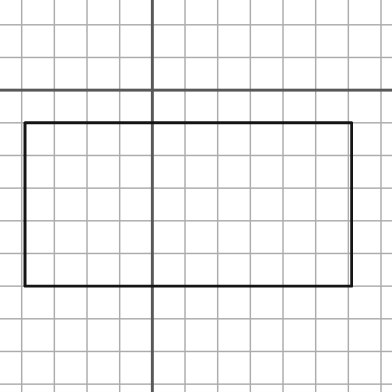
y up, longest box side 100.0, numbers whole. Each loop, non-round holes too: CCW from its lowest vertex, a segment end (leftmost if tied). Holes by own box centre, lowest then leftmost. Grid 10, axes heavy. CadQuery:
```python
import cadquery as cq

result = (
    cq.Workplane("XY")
    .moveTo(-39.0, -60.0)
    .lineTo(61.0, -60.0)
    .lineTo(61.0, -10.0)
    .lineTo(-39.0, -10.0)
    .close()
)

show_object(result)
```